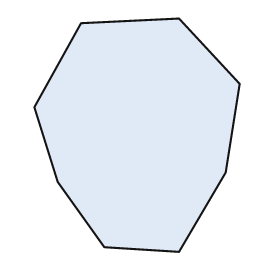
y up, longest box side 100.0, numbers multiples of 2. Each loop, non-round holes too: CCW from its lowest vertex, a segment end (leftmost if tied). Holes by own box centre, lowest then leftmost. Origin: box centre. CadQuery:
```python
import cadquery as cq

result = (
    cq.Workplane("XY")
    .moveTo(18.0, -50.0)
    .lineTo(38.0, -16.0)
    .lineTo(44.0, 22.0)
    .lineTo(18.0, 50.0)
    .lineTo(-24.0, 48.0)
    .lineTo(-44.0, 12.0)
    .lineTo(-34.0, -20.0)
    .lineTo(-14.0, -48.0)
    .close()
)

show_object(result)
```